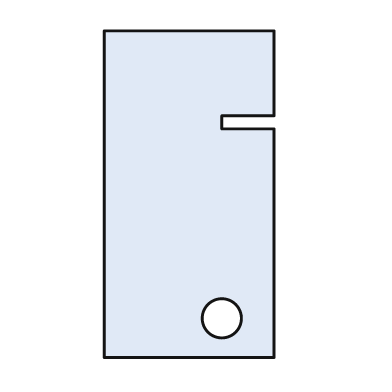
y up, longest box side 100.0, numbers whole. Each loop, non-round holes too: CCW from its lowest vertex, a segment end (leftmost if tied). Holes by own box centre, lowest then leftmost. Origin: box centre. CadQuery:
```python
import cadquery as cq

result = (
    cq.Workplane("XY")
    .moveTo(-26.0, -50.0)
    .lineTo(26.0, -50.0)
    .lineTo(26.0, 20.0)
    .lineTo(10.0, 20.0)
    .lineTo(10.0, 24.0)
    .lineTo(26.0, 24.0)
    .lineTo(26.0, 50.0)
    .lineTo(-26.0, 50.0)
    .close()
    .moveTo(10.0, -38.0)
    .circle(6.0)
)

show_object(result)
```